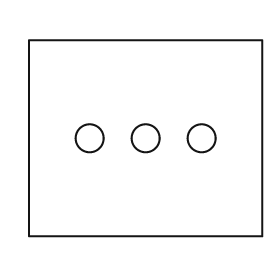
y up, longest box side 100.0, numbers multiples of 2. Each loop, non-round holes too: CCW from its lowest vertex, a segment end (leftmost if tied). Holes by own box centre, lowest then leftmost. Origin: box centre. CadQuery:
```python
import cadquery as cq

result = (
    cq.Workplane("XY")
    .moveTo(-50.0, -42.0)
    .lineTo(50.0, -42.0)
    .lineTo(50.0, 42.0)
    .lineTo(-50.0, 42.0)
    .close()
    .moveTo(-24.0, 0.0)
    .circle(6.0)
    .moveTo(0.0, 0.0)
    .circle(6.0)
    .moveTo(24.0, 0.0)
    .circle(6.0)
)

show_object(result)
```